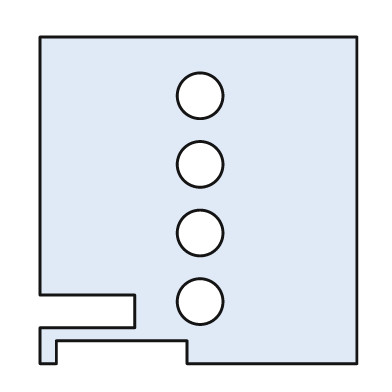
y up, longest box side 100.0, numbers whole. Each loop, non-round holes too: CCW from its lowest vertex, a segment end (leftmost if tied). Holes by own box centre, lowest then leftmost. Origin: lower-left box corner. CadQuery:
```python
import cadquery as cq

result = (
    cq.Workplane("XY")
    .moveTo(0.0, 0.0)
    .lineTo(5.0, 0.0)
    .lineTo(5.0, 7.0)
    .lineTo(45.0, 7.0)
    .lineTo(45.0, 0.0)
    .lineTo(97.0, 0.0)
    .lineTo(97.0, 100.0)
    .lineTo(0.0, 100.0)
    .lineTo(0.0, 21.0)
    .lineTo(29.0, 21.0)
    .lineTo(29.0, 11.0)
    .lineTo(0.0, 11.0)
    .close()
    .moveTo(49.0, 19.0)
    .circle(7.0)
    .moveTo(49.0, 40.0)
    .circle(7.0)
    .moveTo(49.0, 61.0)
    .circle(7.0)
    .moveTo(49.0, 82.0)
    .circle(7.0)
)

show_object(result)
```